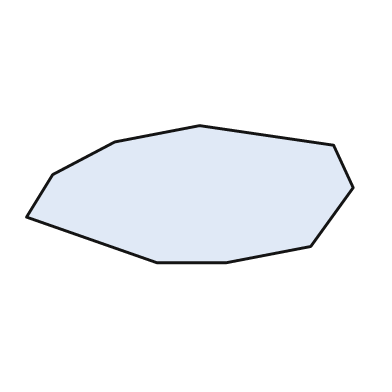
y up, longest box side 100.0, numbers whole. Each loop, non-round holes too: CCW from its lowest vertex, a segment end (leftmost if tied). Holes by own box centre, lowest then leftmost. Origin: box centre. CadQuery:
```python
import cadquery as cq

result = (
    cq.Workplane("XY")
    .moveTo(-10.0, -21.0)
    .lineTo(11.0, -21.0)
    .lineTo(37.0, -16.0)
    .lineTo(50.0, 2.0)
    .lineTo(44.0, 15.0)
    .lineTo(3.0, 21.0)
    .lineTo(-23.0, 16.0)
    .lineTo(-42.0, 6.0)
    .lineTo(-50.0, -7.0)
    .close()
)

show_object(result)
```